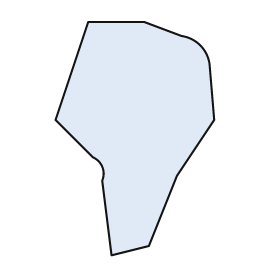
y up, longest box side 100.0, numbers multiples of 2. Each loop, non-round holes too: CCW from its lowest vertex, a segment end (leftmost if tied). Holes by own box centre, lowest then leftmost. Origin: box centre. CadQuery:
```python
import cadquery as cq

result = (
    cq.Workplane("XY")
    .moveTo(-10.0, -50.0)
    .lineTo(6.0, -46.0)
    .lineTo(18.0, -16.0)
    .lineTo(34.0, 8.0)
    .lineTo(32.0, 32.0)
    .threePointArc((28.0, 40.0), (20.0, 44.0))
    .lineTo(4.0, 50.0)
    .lineTo(-20.0, 50.0)
    .lineTo(-34.0, 8.0)
    .lineTo(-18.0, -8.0)
    .threePointArc((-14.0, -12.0), (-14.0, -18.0))
    .close()
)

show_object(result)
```